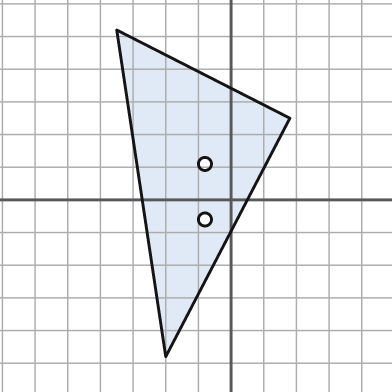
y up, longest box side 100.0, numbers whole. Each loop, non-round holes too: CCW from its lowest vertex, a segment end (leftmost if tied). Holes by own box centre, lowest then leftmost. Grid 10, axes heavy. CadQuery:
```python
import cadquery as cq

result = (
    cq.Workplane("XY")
    .moveTo(-20.0, -48.0)
    .lineTo(18.0, 25.0)
    .lineTo(-35.0, 52.0)
    .close()
    .moveTo(-8.0, -6.0)
    .circle(2.0)
    .moveTo(-8.0, 11.0)
    .circle(2.0)
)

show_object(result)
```